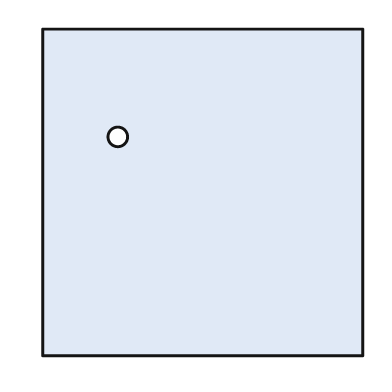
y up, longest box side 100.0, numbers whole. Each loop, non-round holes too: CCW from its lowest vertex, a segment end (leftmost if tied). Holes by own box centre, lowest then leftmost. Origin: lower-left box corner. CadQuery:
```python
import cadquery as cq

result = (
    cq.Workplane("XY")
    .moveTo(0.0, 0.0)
    .lineTo(98.0, 0.0)
    .lineTo(98.0, 100.0)
    .lineTo(0.0, 100.0)
    .close()
    .moveTo(23.0, 67.0)
    .circle(3.0)
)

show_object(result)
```